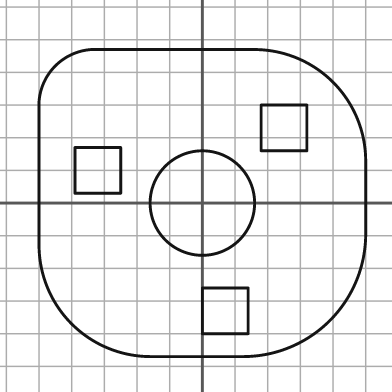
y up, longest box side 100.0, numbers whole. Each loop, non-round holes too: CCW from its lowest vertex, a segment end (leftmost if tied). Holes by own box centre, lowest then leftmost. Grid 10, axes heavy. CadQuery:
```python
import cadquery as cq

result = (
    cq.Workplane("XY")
    .moveTo(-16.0, -47.0)
    .lineTo(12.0, -47.0)
    .threePointArc((39.0, -36.0), (50.0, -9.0))
    .lineTo(50.0, 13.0)
    .threePointArc((40.0, 37.0), (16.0, 47.0))
    .lineTo(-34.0, 47.0)
    .threePointArc((-45.0, 42.0), (-50.0, 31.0))
    .lineTo(-50.0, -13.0)
    .threePointArc((-40.0, -37.0), (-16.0, -47.0))
    .close()
    .moveTo(0.0, -40.0)
    .lineTo(14.0, -40.0)
    .lineTo(14.0, -26.0)
    .lineTo(0.0, -26.0)
    .close()
    .moveTo(0.0, 0.0)
    .circle(16.0)
    .moveTo(-39.0, 3.0)
    .lineTo(-25.0, 3.0)
    .lineTo(-25.0, 17.0)
    .lineTo(-39.0, 17.0)
    .close()
    .moveTo(18.0, 16.0)
    .lineTo(32.0, 16.0)
    .lineTo(32.0, 30.0)
    .lineTo(18.0, 30.0)
    .close()
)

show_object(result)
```